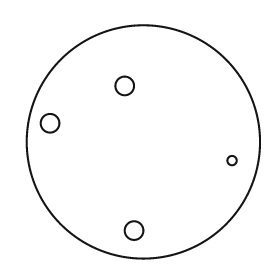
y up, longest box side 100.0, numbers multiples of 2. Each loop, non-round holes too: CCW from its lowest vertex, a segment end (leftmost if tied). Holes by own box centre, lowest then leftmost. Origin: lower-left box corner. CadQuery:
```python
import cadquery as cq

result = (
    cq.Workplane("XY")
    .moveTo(50.0, 50.0)
    .circle(50.0)
    .moveTo(46.0, 12.0)
    .circle(4.0)
    .moveTo(88.0, 42.0)
    .circle(2.0)
    .moveTo(10.0, 58.0)
    .circle(4.0)
    .moveTo(42.0, 74.0)
    .circle(4.0)
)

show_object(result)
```